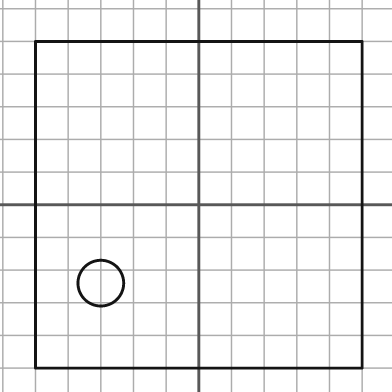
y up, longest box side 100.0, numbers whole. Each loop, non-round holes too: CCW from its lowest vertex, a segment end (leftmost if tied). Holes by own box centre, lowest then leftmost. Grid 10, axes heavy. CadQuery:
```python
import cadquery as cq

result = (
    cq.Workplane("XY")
    .moveTo(-50.0, -50.0)
    .lineTo(50.0, -50.0)
    .lineTo(50.0, 50.0)
    .lineTo(-50.0, 50.0)
    .close()
    .moveTo(-30.0, -24.0)
    .circle(7.0)
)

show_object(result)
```